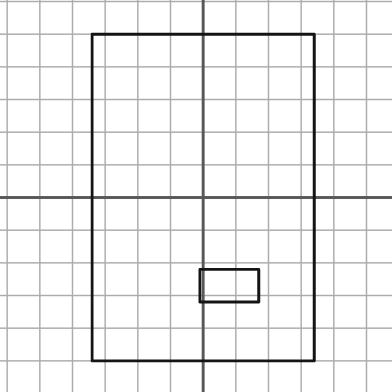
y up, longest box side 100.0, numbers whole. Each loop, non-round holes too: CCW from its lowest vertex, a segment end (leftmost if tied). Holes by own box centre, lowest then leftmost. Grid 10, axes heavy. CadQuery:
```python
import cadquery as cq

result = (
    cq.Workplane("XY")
    .moveTo(-34.0, -50.0)
    .lineTo(34.0, -50.0)
    .lineTo(34.0, 50.0)
    .lineTo(-34.0, 50.0)
    .close()
    .moveTo(-1.0, -32.0)
    .lineTo(17.0, -32.0)
    .lineTo(17.0, -22.0)
    .lineTo(-1.0, -22.0)
    .close()
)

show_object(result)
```